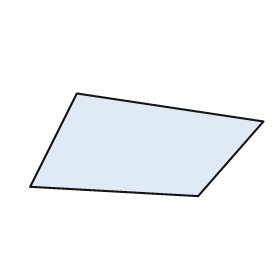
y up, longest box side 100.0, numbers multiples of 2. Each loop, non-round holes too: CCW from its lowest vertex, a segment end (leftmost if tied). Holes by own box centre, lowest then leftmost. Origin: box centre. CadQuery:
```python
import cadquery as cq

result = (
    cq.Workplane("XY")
    .moveTo(22.0, -22.0)
    .lineTo(50.0, 10.0)
    .lineTo(-30.0, 22.0)
    .lineTo(-50.0, -18.0)
    .close()
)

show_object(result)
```